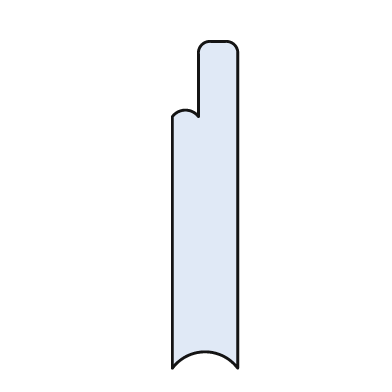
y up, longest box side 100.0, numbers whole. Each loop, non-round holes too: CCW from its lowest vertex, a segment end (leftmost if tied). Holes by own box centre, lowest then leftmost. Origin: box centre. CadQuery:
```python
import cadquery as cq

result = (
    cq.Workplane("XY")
    .moveTo(-10.0, -50.0)
    .threePointArc((0.0, -45.0), (10.0, -50.0))
    .lineTo(10.0, 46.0)
    .threePointArc((9.0, 49.0), (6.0, 50.0))
    .lineTo(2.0, 50.0)
    .threePointArc((-1.0, 49.0), (-2.0, 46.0))
    .lineTo(-2.0, 27.0)
    .threePointArc((-6.0, 29.0), (-10.0, 27.0))
    .close()
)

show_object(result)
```